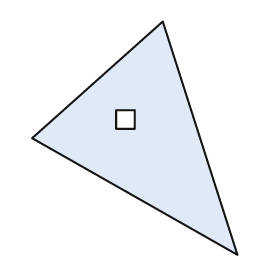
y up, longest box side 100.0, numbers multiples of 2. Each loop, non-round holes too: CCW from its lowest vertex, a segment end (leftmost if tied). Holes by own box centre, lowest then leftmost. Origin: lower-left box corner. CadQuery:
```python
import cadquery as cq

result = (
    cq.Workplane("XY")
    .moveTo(88.0, 0.0)
    .lineTo(56.0, 100.0)
    .lineTo(0.0, 50.0)
    .close()
    .moveTo(36.0, 54.0)
    .lineTo(44.0, 54.0)
    .lineTo(44.0, 62.0)
    .lineTo(36.0, 62.0)
    .close()
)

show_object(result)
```